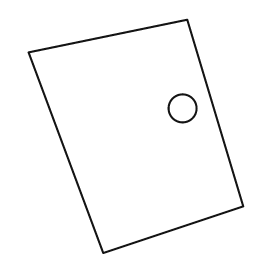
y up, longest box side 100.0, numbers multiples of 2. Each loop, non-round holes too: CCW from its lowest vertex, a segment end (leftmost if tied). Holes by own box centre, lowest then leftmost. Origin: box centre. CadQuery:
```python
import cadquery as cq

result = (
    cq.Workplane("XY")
    .moveTo(-14.0, -50.0)
    .lineTo(46.0, -30.0)
    .lineTo(22.0, 50.0)
    .lineTo(-46.0, 36.0)
    .close()
    .moveTo(20.0, 12.0)
    .circle(6.0)
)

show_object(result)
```